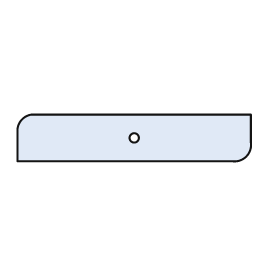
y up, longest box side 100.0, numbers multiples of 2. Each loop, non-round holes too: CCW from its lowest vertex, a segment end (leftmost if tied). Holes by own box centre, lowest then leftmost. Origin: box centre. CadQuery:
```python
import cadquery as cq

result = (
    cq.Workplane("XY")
    .moveTo(-50.0, -10.0)
    .lineTo(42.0, -10.0)
    .threePointArc((48.0, -8.0), (50.0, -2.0))
    .lineTo(50.0, 10.0)
    .lineTo(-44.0, 10.0)
    .threePointArc((-48.0, 8.0), (-50.0, 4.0))
    .close()
    .moveTo(0.0, 0.0)
    .circle(2.0)
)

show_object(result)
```